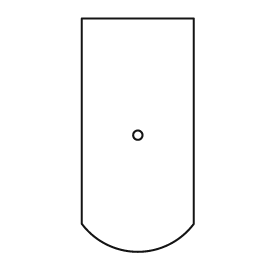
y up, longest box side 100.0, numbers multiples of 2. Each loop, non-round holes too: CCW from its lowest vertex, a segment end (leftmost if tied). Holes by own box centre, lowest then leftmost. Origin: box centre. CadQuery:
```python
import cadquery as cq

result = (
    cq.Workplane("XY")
    .moveTo(-24.0, -38.0)
    .threePointArc((0.0, -50.0), (24.0, -38.0))
    .lineTo(24.0, 50.0)
    .lineTo(-24.0, 50.0)
    .close()
    .moveTo(0.0, 0.0)
    .circle(2.0)
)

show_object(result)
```